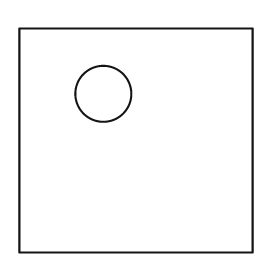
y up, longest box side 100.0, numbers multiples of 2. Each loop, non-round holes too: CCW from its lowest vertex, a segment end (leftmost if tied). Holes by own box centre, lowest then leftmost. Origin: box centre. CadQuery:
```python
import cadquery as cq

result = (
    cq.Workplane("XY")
    .moveTo(-50.0, -48.0)
    .lineTo(50.0, -48.0)
    .lineTo(50.0, 48.0)
    .lineTo(-50.0, 48.0)
    .close()
    .moveTo(-14.0, 20.0)
    .circle(12.0)
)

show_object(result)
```